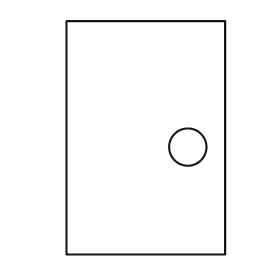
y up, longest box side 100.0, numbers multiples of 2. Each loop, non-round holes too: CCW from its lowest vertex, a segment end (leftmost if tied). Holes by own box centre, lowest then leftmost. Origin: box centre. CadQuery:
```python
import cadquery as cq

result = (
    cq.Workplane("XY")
    .moveTo(-34.0, -50.0)
    .lineTo(34.0, -50.0)
    .lineTo(34.0, 50.0)
    .lineTo(-34.0, 50.0)
    .close()
    .moveTo(18.0, -4.0)
    .circle(8.0)
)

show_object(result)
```